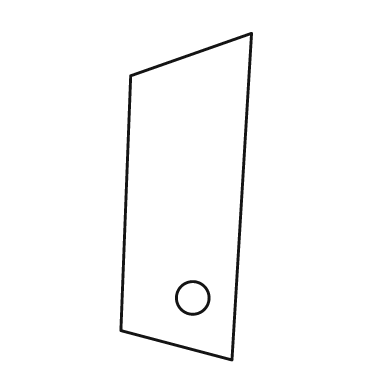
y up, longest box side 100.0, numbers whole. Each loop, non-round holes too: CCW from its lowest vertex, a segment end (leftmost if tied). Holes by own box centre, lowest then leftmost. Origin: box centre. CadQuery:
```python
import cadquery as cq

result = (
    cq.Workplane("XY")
    .moveTo(14.0, -50.0)
    .lineTo(20.0, 50.0)
    .lineTo(-17.0, 37.0)
    .lineTo(-20.0, -41.0)
    .close()
    .moveTo(2.0, -31.0)
    .circle(5.0)
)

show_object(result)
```